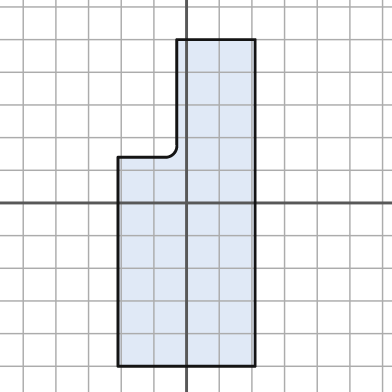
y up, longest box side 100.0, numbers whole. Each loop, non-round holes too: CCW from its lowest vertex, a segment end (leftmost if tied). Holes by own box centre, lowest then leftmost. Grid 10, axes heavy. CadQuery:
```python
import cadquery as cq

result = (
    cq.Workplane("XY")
    .moveTo(-21.0, -50.0)
    .lineTo(21.0, -50.0)
    .lineTo(21.0, 50.0)
    .lineTo(-3.0, 50.0)
    .lineTo(-3.0, 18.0)
    .threePointArc((-4.0, 15.0), (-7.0, 14.0))
    .lineTo(-21.0, 14.0)
    .close()
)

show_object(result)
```